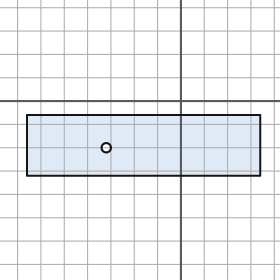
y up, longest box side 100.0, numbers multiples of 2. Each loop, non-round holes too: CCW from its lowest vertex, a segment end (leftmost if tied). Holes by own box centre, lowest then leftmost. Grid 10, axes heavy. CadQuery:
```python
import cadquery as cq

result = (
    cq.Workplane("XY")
    .moveTo(-66.0, -32.0)
    .lineTo(34.0, -32.0)
    .lineTo(34.0, -6.0)
    .lineTo(-66.0, -6.0)
    .close()
    .moveTo(-32.0, -20.0)
    .circle(2.0)
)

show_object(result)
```